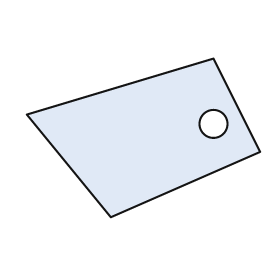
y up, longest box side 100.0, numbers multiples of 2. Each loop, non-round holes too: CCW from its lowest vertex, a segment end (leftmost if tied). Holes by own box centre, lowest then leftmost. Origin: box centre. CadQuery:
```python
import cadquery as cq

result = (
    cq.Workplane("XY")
    .moveTo(-14.0, -34.0)
    .lineTo(50.0, -6.0)
    .lineTo(30.0, 34.0)
    .lineTo(-50.0, 10.0)
    .close()
    .moveTo(30.0, 6.0)
    .circle(6.0)
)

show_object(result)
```